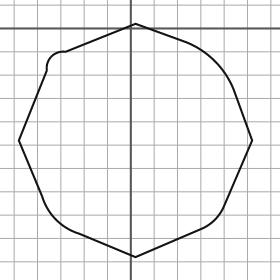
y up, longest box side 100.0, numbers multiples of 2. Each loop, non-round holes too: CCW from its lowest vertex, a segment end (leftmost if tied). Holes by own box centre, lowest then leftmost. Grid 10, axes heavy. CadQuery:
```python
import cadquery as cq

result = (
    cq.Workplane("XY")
    .moveTo(2.0, -98.0)
    .lineTo(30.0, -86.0)
    .threePointArc((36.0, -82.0), (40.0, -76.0))
    .lineTo(52.0, -48.0)
    .lineTo(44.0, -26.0)
    .threePointArc((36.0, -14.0), (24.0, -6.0))
    .lineTo(2.0, 2.0)
    .lineTo(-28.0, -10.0)
    .threePointArc((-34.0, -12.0), (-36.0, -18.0))
    .lineTo(-48.0, -48.0)
    .lineTo(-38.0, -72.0)
    .threePointArc((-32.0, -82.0), (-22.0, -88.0))
    .close()
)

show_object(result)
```